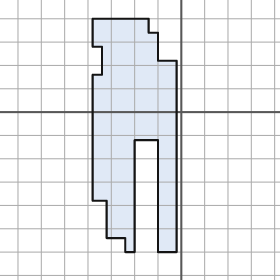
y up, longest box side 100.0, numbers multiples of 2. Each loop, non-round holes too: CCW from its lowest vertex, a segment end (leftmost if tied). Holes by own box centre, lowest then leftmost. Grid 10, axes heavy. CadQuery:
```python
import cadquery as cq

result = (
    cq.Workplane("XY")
    .moveTo(-24.0, -60.0)
    .lineTo(-20.0, -60.0)
    .lineTo(-20.0, -12.0)
    .lineTo(-10.0, -12.0)
    .lineTo(-10.0, -60.0)
    .lineTo(-2.0, -60.0)
    .lineTo(-2.0, 22.0)
    .lineTo(-10.0, 22.0)
    .lineTo(-10.0, 34.0)
    .lineTo(-14.0, 34.0)
    .lineTo(-14.0, 40.0)
    .lineTo(-38.0, 40.0)
    .lineTo(-38.0, 28.0)
    .lineTo(-34.0, 28.0)
    .lineTo(-34.0, 16.0)
    .lineTo(-38.0, 16.0)
    .lineTo(-38.0, -38.0)
    .lineTo(-32.0, -38.0)
    .lineTo(-32.0, -54.0)
    .lineTo(-24.0, -54.0)
    .close()
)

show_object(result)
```